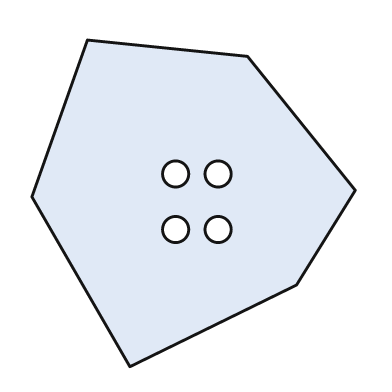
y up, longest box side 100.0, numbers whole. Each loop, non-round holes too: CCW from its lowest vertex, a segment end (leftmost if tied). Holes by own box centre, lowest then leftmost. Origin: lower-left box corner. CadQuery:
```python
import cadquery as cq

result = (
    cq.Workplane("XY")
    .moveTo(30.0, 0.0)
    .lineTo(81.0, 25.0)
    .lineTo(99.0, 54.0)
    .lineTo(66.0, 95.0)
    .lineTo(17.0, 100.0)
    .lineTo(0.0, 52.0)
    .close()
    .moveTo(44.0, 42.0)
    .circle(4.0)
    .moveTo(57.0, 42.0)
    .circle(4.0)
    .moveTo(44.0, 59.0)
    .circle(4.0)
    .moveTo(57.0, 59.0)
    .circle(4.0)
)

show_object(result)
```